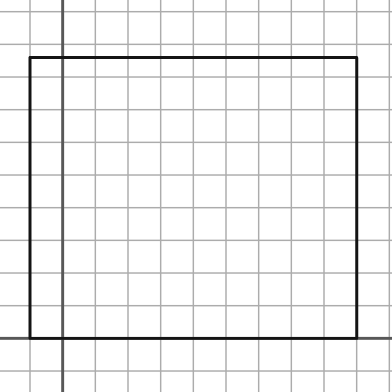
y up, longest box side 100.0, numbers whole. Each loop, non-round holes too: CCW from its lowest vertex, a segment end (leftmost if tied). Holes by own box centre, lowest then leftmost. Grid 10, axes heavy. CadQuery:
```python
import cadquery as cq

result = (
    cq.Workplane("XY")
    .moveTo(-10.0, 0.0)
    .lineTo(90.0, 0.0)
    .lineTo(90.0, 86.0)
    .lineTo(-10.0, 86.0)
    .close()
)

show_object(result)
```